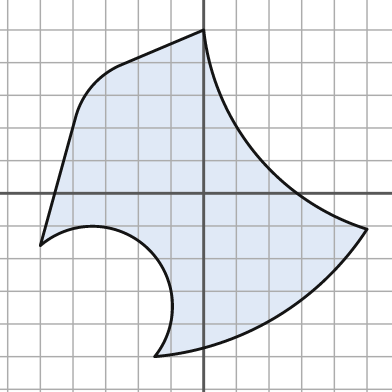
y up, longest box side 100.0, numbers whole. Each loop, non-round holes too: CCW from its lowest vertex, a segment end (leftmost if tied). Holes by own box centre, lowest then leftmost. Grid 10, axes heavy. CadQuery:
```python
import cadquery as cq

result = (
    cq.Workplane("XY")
    .moveTo(-15.0, -50.0)
    .threePointArc((22.0, -38.0), (50.0, -11.0))
    .threePointArc((16.0, 12.0), (0.0, 50.0))
    .lineTo(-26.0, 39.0)
    .threePointArc((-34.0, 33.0), (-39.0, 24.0))
    .lineTo(-50.0, -16.0)
    .threePointArc((-17.0, -17.0), (-15.0, -50.0))
    .close()
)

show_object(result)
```